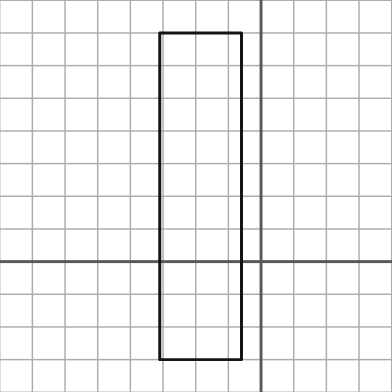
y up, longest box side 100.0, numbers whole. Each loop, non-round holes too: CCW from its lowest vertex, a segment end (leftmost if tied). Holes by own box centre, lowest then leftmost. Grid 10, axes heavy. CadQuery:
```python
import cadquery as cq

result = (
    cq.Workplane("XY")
    .moveTo(-31.0, -30.0)
    .lineTo(-6.0, -30.0)
    .lineTo(-6.0, 70.0)
    .lineTo(-31.0, 70.0)
    .close()
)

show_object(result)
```